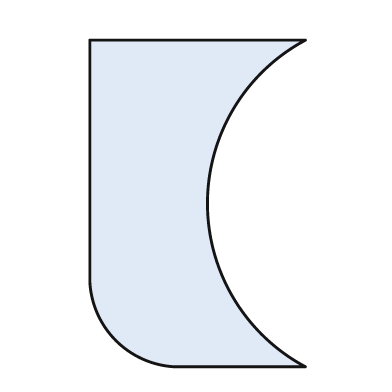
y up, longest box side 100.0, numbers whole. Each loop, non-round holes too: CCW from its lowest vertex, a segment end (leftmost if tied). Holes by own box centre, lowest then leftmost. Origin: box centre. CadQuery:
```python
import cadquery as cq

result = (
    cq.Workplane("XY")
    .moveTo(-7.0, -50.0)
    .lineTo(33.0, -50.0)
    .threePointArc((3.0, 0.0), (33.0, 50.0))
    .lineTo(-33.0, 50.0)
    .lineTo(-33.0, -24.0)
    .threePointArc((-25.0, -42.0), (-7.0, -50.0))
    .close()
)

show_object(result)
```